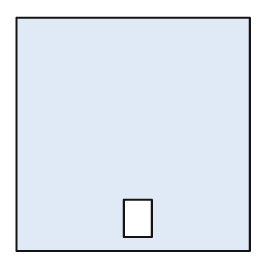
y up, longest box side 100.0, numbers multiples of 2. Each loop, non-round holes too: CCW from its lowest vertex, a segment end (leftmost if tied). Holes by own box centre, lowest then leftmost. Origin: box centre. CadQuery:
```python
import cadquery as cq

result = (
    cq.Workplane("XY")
    .moveTo(-50.0, -50.0)
    .lineTo(50.0, -50.0)
    .lineTo(50.0, 50.0)
    .lineTo(-50.0, 50.0)
    .close()
    .moveTo(-4.0, -44.0)
    .lineTo(8.0, -44.0)
    .lineTo(8.0, -28.0)
    .lineTo(-4.0, -28.0)
    .close()
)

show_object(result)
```